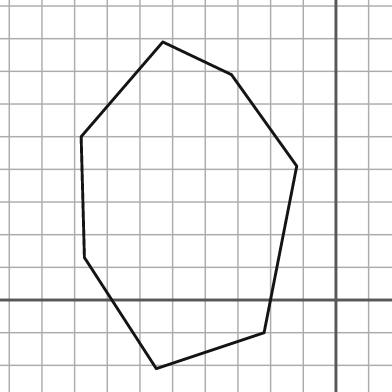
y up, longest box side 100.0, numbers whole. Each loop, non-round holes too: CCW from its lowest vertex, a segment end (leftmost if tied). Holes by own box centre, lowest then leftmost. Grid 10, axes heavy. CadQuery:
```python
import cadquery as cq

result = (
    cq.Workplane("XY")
    .moveTo(-55.0, -21.0)
    .lineTo(-22.0, -10.0)
    .lineTo(-12.0, 41.0)
    .lineTo(-32.0, 69.0)
    .lineTo(-53.0, 79.0)
    .lineTo(-78.0, 50.0)
    .lineTo(-77.0, 13.0)
    .close()
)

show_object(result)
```